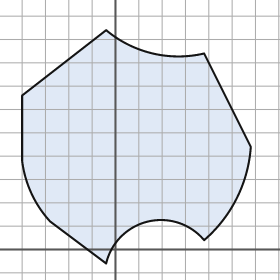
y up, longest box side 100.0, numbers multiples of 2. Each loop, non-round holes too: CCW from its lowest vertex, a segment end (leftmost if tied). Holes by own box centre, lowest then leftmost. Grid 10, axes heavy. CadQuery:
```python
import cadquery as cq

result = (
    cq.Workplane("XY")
    .moveTo(-4.0, -6.0)
    .threePointArc((14.0, 12.0), (38.0, 4.0))
    .threePointArc((52.0, 22.0), (58.0, 44.0))
    .lineTo(38.0, 84.0)
    .threePointArc((16.0, 84.0), (-4.0, 94.0))
    .lineTo(-40.0, 66.0)
    .lineTo(-40.0, 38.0)
    .threePointArc((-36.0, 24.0), (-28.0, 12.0))
    .close()
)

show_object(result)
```